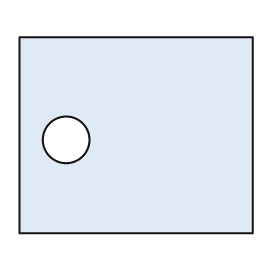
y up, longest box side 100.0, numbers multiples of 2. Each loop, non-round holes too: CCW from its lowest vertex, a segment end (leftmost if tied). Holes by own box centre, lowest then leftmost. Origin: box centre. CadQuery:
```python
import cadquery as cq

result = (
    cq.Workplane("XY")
    .moveTo(-50.0, -42.0)
    .lineTo(50.0, -42.0)
    .lineTo(50.0, 42.0)
    .lineTo(-50.0, 42.0)
    .close()
    .moveTo(-30.0, -2.0)
    .circle(10.0)
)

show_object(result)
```